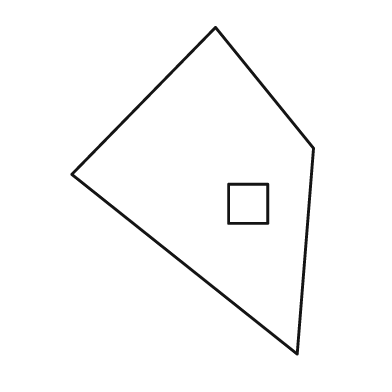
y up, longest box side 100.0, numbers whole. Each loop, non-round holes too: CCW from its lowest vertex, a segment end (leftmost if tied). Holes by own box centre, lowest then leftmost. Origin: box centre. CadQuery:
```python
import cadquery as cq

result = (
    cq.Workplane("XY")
    .moveTo(32.0, -50.0)
    .lineTo(37.0, 13.0)
    .lineTo(7.0, 50.0)
    .lineTo(-37.0, 5.0)
    .close()
    .moveTo(11.0, -10.0)
    .lineTo(23.0, -10.0)
    .lineTo(23.0, 2.0)
    .lineTo(11.0, 2.0)
    .close()
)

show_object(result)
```